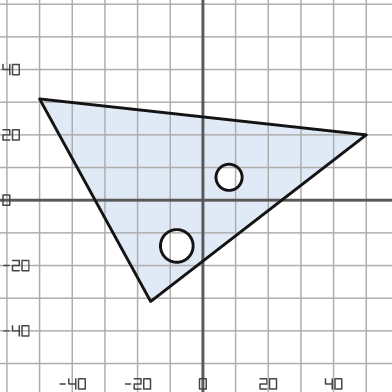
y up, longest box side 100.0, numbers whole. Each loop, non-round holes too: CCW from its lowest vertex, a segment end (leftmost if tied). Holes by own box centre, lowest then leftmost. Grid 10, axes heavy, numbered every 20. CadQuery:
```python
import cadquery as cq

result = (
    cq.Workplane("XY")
    .moveTo(-16.0, -31.0)
    .lineTo(50.0, 20.0)
    .lineTo(-50.0, 31.0)
    .close()
    .moveTo(-8.0, -14.0)
    .circle(5.0)
    .moveTo(8.0, 7.0)
    .circle(4.0)
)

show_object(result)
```